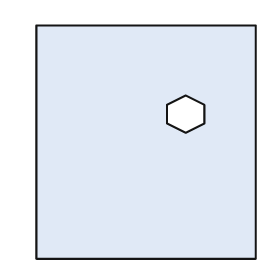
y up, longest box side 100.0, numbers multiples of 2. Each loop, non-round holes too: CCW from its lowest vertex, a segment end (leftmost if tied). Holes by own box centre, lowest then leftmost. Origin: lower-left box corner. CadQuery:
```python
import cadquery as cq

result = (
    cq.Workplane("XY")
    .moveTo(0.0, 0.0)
    .lineTo(94.0, 0.0)
    .lineTo(94.0, 100.0)
    .lineTo(0.0, 100.0)
    .close()
    .moveTo(64.0, 54.0)
    .lineTo(72.0, 58.0)
    .lineTo(72.0, 66.0)
    .lineTo(64.0, 70.0)
    .lineTo(56.0, 66.0)
    .lineTo(56.0, 58.0)
    .close()
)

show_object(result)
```